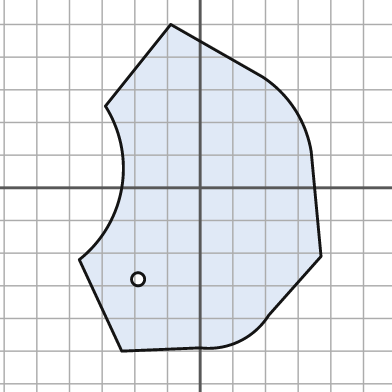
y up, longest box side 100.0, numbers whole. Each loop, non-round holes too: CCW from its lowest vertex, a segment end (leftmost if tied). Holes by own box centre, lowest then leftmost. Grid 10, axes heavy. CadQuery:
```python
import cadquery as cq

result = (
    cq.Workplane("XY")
    .moveTo(-24.0, -50.0)
    .lineTo(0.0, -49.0)
    .threePointArc((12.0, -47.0), (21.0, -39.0))
    .lineTo(37.0, -21.0)
    .lineTo(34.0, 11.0)
    .threePointArc((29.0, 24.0), (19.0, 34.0))
    .lineTo(-9.0, 50.0)
    .lineTo(-29.0, 25.0)
    .threePointArc((-24.0, 0.0), (-37.0, -22.0))
    .close()
    .moveTo(-19.0, -28.0)
    .circle(2.0)
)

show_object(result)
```